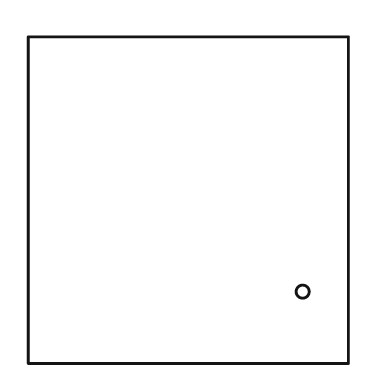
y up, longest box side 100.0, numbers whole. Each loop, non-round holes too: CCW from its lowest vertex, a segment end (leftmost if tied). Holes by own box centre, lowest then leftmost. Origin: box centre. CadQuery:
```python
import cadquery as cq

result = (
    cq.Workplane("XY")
    .moveTo(-49.0, -50.0)
    .lineTo(49.0, -50.0)
    .lineTo(49.0, 50.0)
    .lineTo(-49.0, 50.0)
    .close()
    .moveTo(35.0, -28.0)
    .circle(2.0)
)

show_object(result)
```